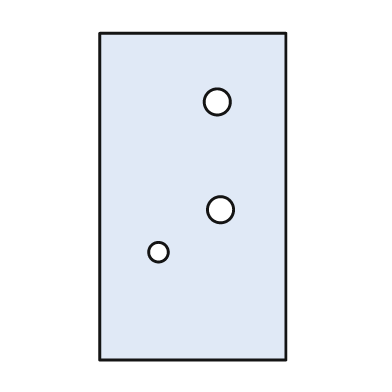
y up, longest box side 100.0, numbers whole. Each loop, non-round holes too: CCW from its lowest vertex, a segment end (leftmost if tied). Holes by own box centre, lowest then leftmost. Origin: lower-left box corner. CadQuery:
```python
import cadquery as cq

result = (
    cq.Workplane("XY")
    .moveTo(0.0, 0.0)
    .lineTo(57.0, 0.0)
    .lineTo(57.0, 100.0)
    .lineTo(0.0, 100.0)
    .close()
    .moveTo(18.0, 33.0)
    .circle(3.0)
    .moveTo(37.0, 46.0)
    .circle(4.0)
    .moveTo(36.0, 79.0)
    .circle(4.0)
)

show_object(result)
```